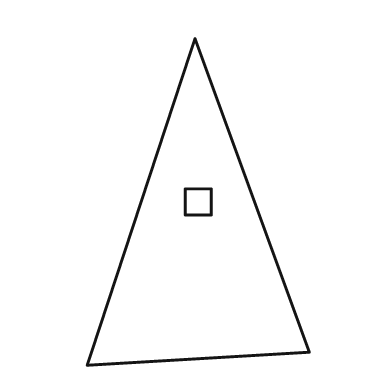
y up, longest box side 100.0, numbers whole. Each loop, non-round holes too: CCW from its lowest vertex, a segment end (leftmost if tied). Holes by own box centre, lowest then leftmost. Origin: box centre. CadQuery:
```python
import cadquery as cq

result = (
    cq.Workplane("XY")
    .moveTo(-34.0, -50.0)
    .lineTo(34.0, -46.0)
    .lineTo(-1.0, 50.0)
    .close()
    .moveTo(-4.0, -4.0)
    .lineTo(4.0, -4.0)
    .lineTo(4.0, 4.0)
    .lineTo(-4.0, 4.0)
    .close()
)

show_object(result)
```